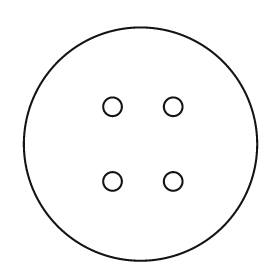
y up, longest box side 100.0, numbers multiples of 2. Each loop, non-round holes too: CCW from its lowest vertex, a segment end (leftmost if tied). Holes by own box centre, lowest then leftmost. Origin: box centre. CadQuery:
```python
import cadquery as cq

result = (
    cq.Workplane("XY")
    .moveTo(0.0, 0.0)
    .circle(50.0)
    .moveTo(-12.0, -16.0)
    .circle(4.0)
    .moveTo(14.0, -16.0)
    .circle(4.0)
    .moveTo(-12.0, 16.0)
    .circle(4.0)
    .moveTo(14.0, 16.0)
    .circle(4.0)
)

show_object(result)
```